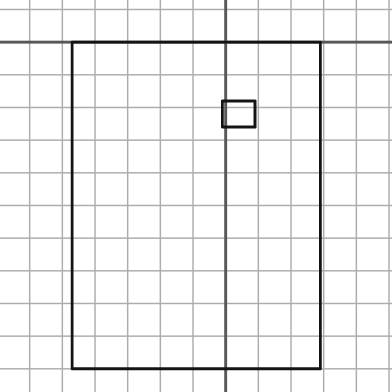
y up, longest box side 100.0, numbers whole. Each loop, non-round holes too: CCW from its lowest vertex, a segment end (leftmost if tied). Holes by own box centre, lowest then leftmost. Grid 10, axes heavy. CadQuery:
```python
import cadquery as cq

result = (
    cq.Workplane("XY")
    .moveTo(-47.0, -100.0)
    .lineTo(29.0, -100.0)
    .lineTo(29.0, 0.0)
    .lineTo(-47.0, 0.0)
    .close()
    .moveTo(-1.0, -26.0)
    .lineTo(9.0, -26.0)
    .lineTo(9.0, -18.0)
    .lineTo(-1.0, -18.0)
    .close()
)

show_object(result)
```